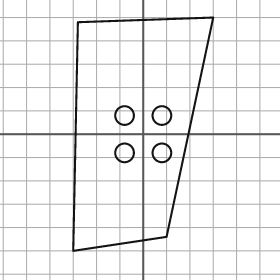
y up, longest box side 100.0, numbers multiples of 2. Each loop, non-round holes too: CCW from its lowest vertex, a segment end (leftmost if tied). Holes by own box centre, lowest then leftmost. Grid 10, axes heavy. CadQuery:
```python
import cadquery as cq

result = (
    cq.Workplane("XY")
    .moveTo(-30.0, -50.0)
    .lineTo(10.0, -44.0)
    .lineTo(30.0, 50.0)
    .lineTo(-28.0, 48.0)
    .close()
    .moveTo(-8.0, -8.0)
    .circle(4.0)
    .moveTo(8.0, -8.0)
    .circle(4.0)
    .moveTo(-8.0, 8.0)
    .circle(4.0)
    .moveTo(8.0, 8.0)
    .circle(4.0)
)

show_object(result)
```